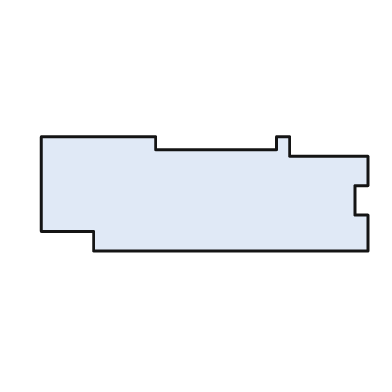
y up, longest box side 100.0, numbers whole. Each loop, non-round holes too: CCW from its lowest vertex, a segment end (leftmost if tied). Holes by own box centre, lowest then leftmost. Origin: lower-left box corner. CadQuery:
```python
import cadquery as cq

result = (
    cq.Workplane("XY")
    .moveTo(16.0, 0.0)
    .lineTo(100.0, 0.0)
    .lineTo(100.0, 11.0)
    .lineTo(96.0, 11.0)
    .lineTo(96.0, 20.0)
    .lineTo(100.0, 20.0)
    .lineTo(100.0, 29.0)
    .lineTo(76.0, 29.0)
    .lineTo(76.0, 35.0)
    .lineTo(72.0, 35.0)
    .lineTo(72.0, 31.0)
    .lineTo(35.0, 31.0)
    .lineTo(35.0, 35.0)
    .lineTo(0.0, 35.0)
    .lineTo(0.0, 6.0)
    .lineTo(16.0, 6.0)
    .close()
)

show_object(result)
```